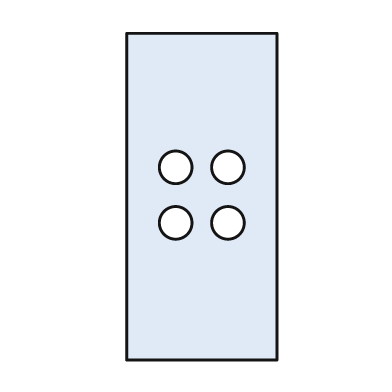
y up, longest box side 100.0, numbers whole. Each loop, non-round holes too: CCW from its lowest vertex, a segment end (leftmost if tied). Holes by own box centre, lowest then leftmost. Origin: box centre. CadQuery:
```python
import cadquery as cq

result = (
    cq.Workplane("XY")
    .moveTo(-23.0, -50.0)
    .lineTo(23.0, -50.0)
    .lineTo(23.0, 50.0)
    .lineTo(-23.0, 50.0)
    .close()
    .moveTo(-8.0, -8.0)
    .circle(5.0)
    .moveTo(8.0, -8.0)
    .circle(5.0)
    .moveTo(-8.0, 9.0)
    .circle(5.0)
    .moveTo(8.0, 9.0)
    .circle(5.0)
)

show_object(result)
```